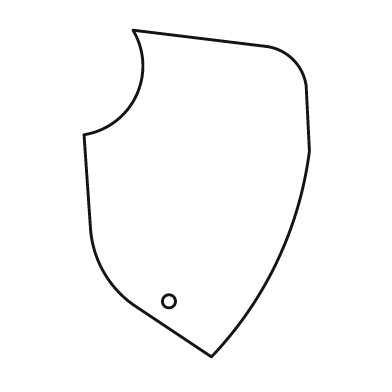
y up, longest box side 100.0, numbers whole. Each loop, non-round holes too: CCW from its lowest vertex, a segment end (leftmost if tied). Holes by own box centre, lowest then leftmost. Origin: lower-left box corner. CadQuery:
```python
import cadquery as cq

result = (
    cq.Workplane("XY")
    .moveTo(39.0, 0.0)
    .threePointArc((59.0, 29.0), (69.0, 63.0))
    .lineTo(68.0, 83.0)
    .threePointArc((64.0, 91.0), (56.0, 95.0))
    .lineTo(15.0, 100.0)
    .threePointArc((16.0, 80.0), (0.0, 68.0))
    .lineTo(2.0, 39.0)
    .threePointArc((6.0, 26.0), (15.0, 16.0))
    .close()
    .moveTo(26.0, 17.0)
    .circle(2.0)
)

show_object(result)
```